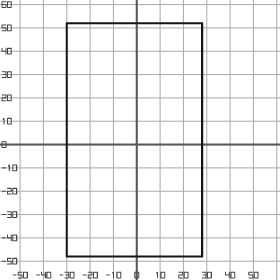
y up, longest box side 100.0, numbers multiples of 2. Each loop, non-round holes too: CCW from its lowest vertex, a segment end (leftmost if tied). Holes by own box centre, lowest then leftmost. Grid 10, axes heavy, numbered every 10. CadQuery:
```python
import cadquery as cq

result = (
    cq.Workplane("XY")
    .moveTo(-30.0, -48.0)
    .lineTo(28.0, -48.0)
    .lineTo(28.0, 52.0)
    .lineTo(-30.0, 52.0)
    .close()
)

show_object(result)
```